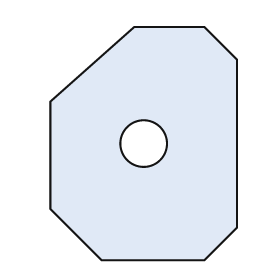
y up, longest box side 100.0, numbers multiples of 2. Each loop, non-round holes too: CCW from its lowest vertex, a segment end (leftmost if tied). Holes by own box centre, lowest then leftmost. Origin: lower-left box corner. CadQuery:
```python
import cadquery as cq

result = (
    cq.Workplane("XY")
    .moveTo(22.0, 0.0)
    .lineTo(66.0, 0.0)
    .lineTo(80.0, 14.0)
    .lineTo(80.0, 86.0)
    .lineTo(66.0, 100.0)
    .lineTo(36.0, 100.0)
    .lineTo(0.0, 68.0)
    .lineTo(0.0, 22.0)
    .close()
    .moveTo(40.0, 50.0)
    .circle(10.0)
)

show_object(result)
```